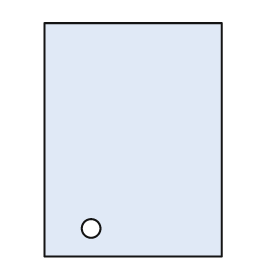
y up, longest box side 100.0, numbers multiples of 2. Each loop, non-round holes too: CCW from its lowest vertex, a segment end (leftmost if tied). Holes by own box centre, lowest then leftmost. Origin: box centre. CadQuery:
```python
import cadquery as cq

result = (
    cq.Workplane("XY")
    .moveTo(-38.0, -50.0)
    .lineTo(38.0, -50.0)
    .lineTo(38.0, 50.0)
    .lineTo(-38.0, 50.0)
    .close()
    .moveTo(-18.0, -38.0)
    .circle(4.0)
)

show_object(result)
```